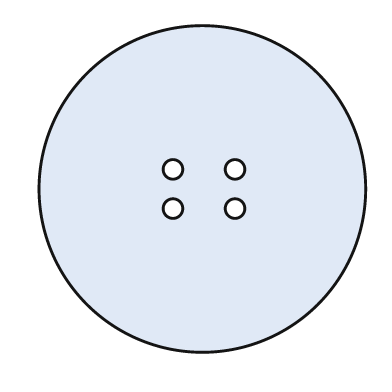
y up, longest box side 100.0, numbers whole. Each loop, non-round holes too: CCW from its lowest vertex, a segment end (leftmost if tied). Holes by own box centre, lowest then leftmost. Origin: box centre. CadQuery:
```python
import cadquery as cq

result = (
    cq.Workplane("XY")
    .moveTo(0.0, 0.0)
    .circle(50.0)
    .moveTo(-9.0, -6.0)
    .circle(3.0)
    .moveTo(10.0, -6.0)
    .circle(3.0)
    .moveTo(-9.0, 6.0)
    .circle(3.0)
    .moveTo(10.0, 6.0)
    .circle(3.0)
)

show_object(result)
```